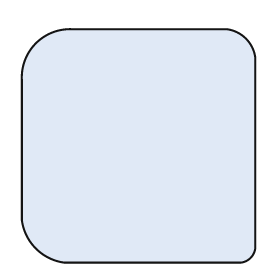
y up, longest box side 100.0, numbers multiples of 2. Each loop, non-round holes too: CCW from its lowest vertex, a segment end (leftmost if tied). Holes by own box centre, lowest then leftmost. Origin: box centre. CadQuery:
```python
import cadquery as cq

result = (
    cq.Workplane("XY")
    .moveTo(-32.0, -50.0)
    .lineTo(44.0, -50.0)
    .threePointArc((48.0, -48.0), (50.0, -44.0))
    .lineTo(50.0, 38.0)
    .threePointArc((46.0, 46.0), (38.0, 50.0))
    .lineTo(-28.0, 50.0)
    .threePointArc((-44.0, 44.0), (-50.0, 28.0))
    .lineTo(-50.0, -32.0)
    .threePointArc((-44.0, -44.0), (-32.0, -50.0))
    .close()
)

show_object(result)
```